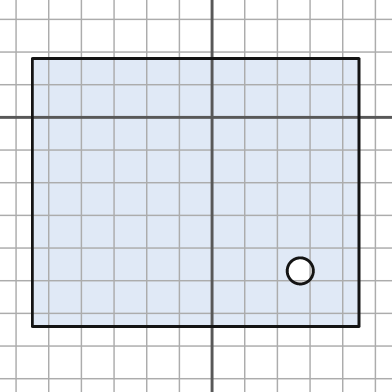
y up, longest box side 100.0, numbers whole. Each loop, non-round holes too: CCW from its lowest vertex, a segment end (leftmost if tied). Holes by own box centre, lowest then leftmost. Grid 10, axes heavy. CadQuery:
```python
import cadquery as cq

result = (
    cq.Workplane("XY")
    .moveTo(-55.0, -64.0)
    .lineTo(45.0, -64.0)
    .lineTo(45.0, 18.0)
    .lineTo(-55.0, 18.0)
    .close()
    .moveTo(27.0, -47.0)
    .circle(4.0)
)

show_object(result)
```